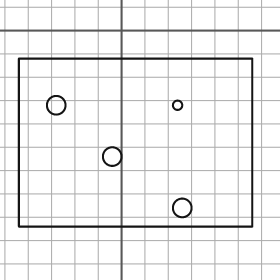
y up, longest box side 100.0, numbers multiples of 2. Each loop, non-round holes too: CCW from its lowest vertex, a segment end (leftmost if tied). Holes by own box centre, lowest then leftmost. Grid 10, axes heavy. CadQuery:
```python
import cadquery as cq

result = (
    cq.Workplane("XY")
    .moveTo(-44.0, -84.0)
    .lineTo(56.0, -84.0)
    .lineTo(56.0, -12.0)
    .lineTo(-44.0, -12.0)
    .close()
    .moveTo(26.0, -76.0)
    .circle(4.0)
    .moveTo(-4.0, -54.0)
    .circle(4.0)
    .moveTo(-28.0, -32.0)
    .circle(4.0)
    .moveTo(24.0, -32.0)
    .circle(2.0)
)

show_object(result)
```